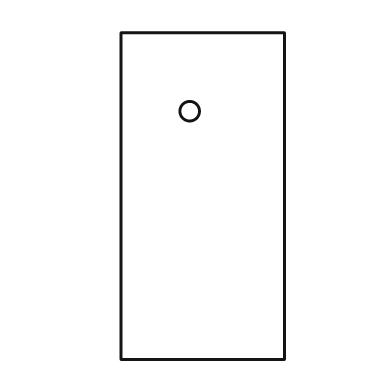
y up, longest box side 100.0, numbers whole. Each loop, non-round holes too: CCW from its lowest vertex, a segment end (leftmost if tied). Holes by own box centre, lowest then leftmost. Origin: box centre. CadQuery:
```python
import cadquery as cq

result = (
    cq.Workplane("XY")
    .moveTo(-25.0, -50.0)
    .lineTo(25.0, -50.0)
    .lineTo(25.0, 50.0)
    .lineTo(-25.0, 50.0)
    .close()
    .moveTo(-4.0, 26.0)
    .circle(3.0)
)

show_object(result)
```